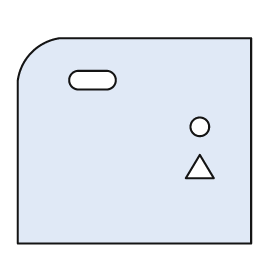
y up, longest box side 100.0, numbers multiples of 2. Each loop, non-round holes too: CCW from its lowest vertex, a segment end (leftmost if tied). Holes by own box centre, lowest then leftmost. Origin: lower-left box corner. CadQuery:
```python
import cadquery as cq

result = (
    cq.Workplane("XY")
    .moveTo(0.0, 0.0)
    .lineTo(100.0, 0.0)
    .lineTo(100.0, 88.0)
    .lineTo(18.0, 88.0)
    .threePointArc((6.0, 82.0), (0.0, 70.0))
    .close()
    .moveTo(72.0, 28.0)
    .lineTo(84.0, 28.0)
    .lineTo(78.0, 38.0)
    .close()
    .moveTo(78.0, 50.0)
    .circle(4.0)
    .moveTo(26.0, 66.0)
    .lineTo(38.0, 66.0)
    .threePointArc((42.0, 70.0), (38.0, 74.0))
    .lineTo(26.0, 74.0)
    .threePointArc((22.0, 70.0), (26.0, 66.0))
    .close()
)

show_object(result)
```